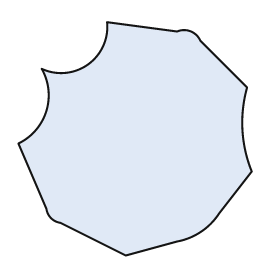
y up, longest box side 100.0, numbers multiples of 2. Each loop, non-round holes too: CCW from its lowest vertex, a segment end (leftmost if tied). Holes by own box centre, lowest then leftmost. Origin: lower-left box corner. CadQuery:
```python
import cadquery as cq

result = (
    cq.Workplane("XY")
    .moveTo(46.0, 0.0)
    .lineTo(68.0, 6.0)
    .threePointArc((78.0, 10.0), (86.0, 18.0))
    .lineTo(100.0, 36.0)
    .threePointArc((96.0, 54.0), (98.0, 72.0))
    .lineTo(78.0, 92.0)
    .threePointArc((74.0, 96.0), (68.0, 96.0))
    .lineTo(38.0, 100.0)
    .threePointArc((30.0, 82.0), (10.0, 80.0))
    .threePointArc((12.0, 62.0), (0.0, 48.0))
    .lineTo(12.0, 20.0)
    .threePointArc((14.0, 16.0), (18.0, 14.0))
    .close()
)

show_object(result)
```